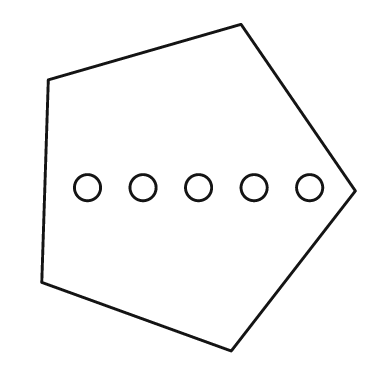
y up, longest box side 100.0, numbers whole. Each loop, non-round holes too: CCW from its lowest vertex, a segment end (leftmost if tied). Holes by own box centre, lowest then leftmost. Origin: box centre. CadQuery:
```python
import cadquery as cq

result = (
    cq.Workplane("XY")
    .moveTo(10.0, -50.0)
    .lineTo(48.0, -1.0)
    .lineTo(13.0, 50.0)
    .lineTo(-46.0, 33.0)
    .lineTo(-48.0, -29.0)
    .close()
    .moveTo(-34.0, 0.0)
    .circle(4.0)
    .moveTo(-17.0, 0.0)
    .circle(4.0)
    .moveTo(0.0, 0.0)
    .circle(4.0)
    .moveTo(17.0, 0.0)
    .circle(4.0)
    .moveTo(34.0, 0.0)
    .circle(4.0)
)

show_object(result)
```